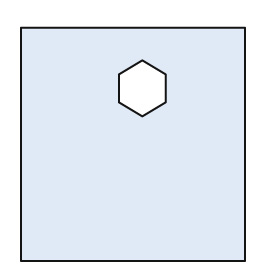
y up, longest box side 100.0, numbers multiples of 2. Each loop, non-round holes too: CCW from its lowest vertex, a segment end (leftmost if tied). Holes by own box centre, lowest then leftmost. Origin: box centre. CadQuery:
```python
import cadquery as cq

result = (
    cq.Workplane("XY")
    .moveTo(-48.0, -50.0)
    .lineTo(48.0, -50.0)
    .lineTo(48.0, 50.0)
    .lineTo(-48.0, 50.0)
    .close()
    .moveTo(4.0, 12.0)
    .lineTo(14.0, 18.0)
    .lineTo(14.0, 30.0)
    .lineTo(4.0, 36.0)
    .lineTo(-6.0, 30.0)
    .lineTo(-6.0, 18.0)
    .close()
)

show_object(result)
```